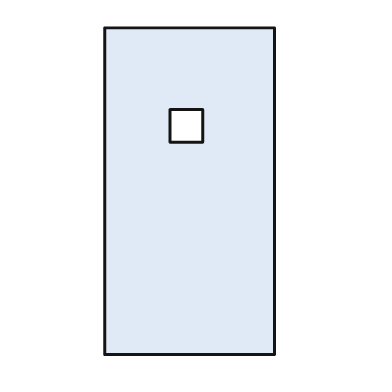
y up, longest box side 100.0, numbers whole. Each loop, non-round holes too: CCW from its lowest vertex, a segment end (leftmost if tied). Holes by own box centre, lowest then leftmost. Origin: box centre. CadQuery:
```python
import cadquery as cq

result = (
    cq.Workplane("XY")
    .moveTo(-26.0, -50.0)
    .lineTo(26.0, -50.0)
    .lineTo(26.0, 50.0)
    .lineTo(-26.0, 50.0)
    .close()
    .moveTo(-6.0, 15.0)
    .lineTo(4.0, 15.0)
    .lineTo(4.0, 25.0)
    .lineTo(-6.0, 25.0)
    .close()
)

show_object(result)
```